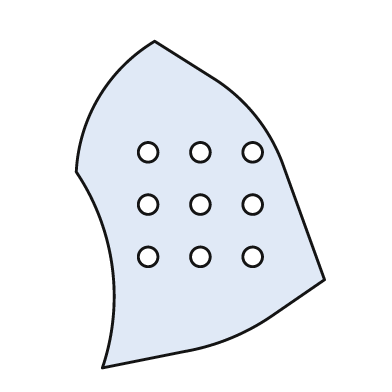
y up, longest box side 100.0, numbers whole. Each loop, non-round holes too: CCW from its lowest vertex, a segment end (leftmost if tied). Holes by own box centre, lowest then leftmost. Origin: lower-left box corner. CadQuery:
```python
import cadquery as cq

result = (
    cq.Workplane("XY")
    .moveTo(8.0, 0.0)
    .lineTo(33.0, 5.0)
    .threePointArc((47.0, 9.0), (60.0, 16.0))
    .lineTo(76.0, 27.0)
    .lineTo(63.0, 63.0)
    .threePointArc((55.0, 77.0), (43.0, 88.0))
    .lineTo(24.0, 100.0)
    .threePointArc((7.0, 83.0), (0.0, 60.0))
    .threePointArc((11.0, 31.0), (8.0, 0.0))
    .close()
    .moveTo(22.0, 34.0)
    .circle(3.0)
    .moveTo(38.0, 34.0)
    .circle(3.0)
    .moveTo(54.0, 34.0)
    .circle(3.0)
    .moveTo(22.0, 50.0)
    .circle(3.0)
    .moveTo(38.0, 50.0)
    .circle(3.0)
    .moveTo(54.0, 50.0)
    .circle(3.0)
    .moveTo(22.0, 66.0)
    .circle(3.0)
    .moveTo(38.0, 66.0)
    .circle(3.0)
    .moveTo(54.0, 66.0)
    .circle(3.0)
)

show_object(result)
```